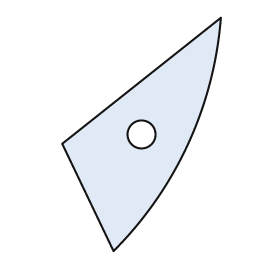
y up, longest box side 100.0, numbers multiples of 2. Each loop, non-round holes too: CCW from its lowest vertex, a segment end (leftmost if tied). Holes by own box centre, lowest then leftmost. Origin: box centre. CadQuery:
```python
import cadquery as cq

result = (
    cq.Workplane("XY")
    .moveTo(-12.0, -50.0)
    .threePointArc((20.0, -4.0), (34.0, 50.0))
    .lineTo(-34.0, -4.0)
    .close()
    .moveTo(0.0, 0.0)
    .circle(6.0)
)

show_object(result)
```